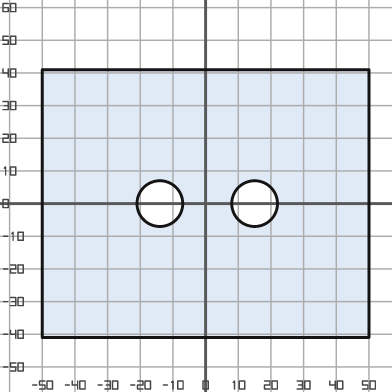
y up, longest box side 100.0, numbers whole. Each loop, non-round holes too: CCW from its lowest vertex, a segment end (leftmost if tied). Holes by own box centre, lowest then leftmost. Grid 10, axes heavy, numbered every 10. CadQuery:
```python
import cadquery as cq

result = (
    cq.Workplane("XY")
    .moveTo(-50.0, -41.0)
    .lineTo(50.0, -41.0)
    .lineTo(50.0, 41.0)
    .lineTo(-50.0, 41.0)
    .close()
    .moveTo(-14.0, 0.0)
    .circle(7.0)
    .moveTo(15.0, 0.0)
    .circle(7.0)
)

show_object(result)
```